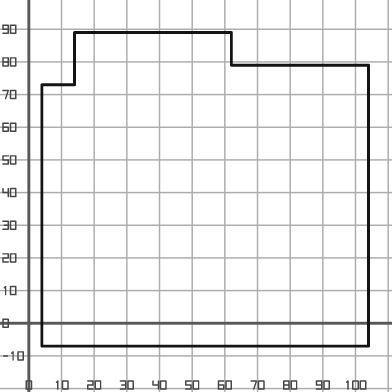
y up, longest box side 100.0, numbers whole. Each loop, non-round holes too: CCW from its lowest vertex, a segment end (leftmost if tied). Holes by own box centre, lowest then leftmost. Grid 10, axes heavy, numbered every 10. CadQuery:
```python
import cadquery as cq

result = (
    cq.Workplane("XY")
    .moveTo(4.0, -7.0)
    .lineTo(104.0, -7.0)
    .lineTo(104.0, 79.0)
    .lineTo(62.0, 79.0)
    .lineTo(62.0, 89.0)
    .lineTo(14.0, 89.0)
    .lineTo(14.0, 73.0)
    .lineTo(4.0, 73.0)
    .close()
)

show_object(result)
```